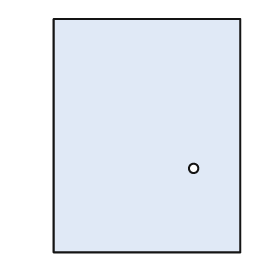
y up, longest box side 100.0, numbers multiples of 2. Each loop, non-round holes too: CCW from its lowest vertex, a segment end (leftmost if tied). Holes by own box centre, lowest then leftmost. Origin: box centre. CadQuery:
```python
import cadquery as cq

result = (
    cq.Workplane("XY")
    .moveTo(-40.0, -50.0)
    .lineTo(40.0, -50.0)
    .lineTo(40.0, 50.0)
    .lineTo(-40.0, 50.0)
    .close()
    .moveTo(20.0, -14.0)
    .circle(2.0)
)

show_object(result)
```